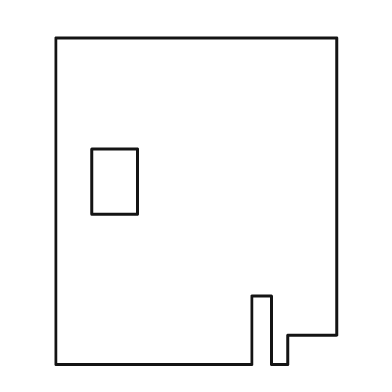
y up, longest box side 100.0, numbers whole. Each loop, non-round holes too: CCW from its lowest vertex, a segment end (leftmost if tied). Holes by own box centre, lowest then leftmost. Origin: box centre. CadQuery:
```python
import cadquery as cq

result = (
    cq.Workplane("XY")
    .moveTo(-43.0, -50.0)
    .lineTo(17.0, -50.0)
    .lineTo(17.0, -29.0)
    .lineTo(23.0, -29.0)
    .lineTo(23.0, -50.0)
    .lineTo(28.0, -50.0)
    .lineTo(28.0, -41.0)
    .lineTo(43.0, -41.0)
    .lineTo(43.0, 50.0)
    .lineTo(-43.0, 50.0)
    .close()
    .moveTo(-32.0, -4.0)
    .lineTo(-18.0, -4.0)
    .lineTo(-18.0, 16.0)
    .lineTo(-32.0, 16.0)
    .close()
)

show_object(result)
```